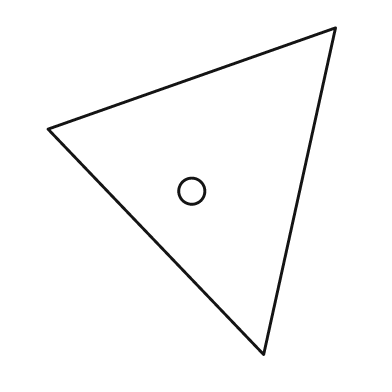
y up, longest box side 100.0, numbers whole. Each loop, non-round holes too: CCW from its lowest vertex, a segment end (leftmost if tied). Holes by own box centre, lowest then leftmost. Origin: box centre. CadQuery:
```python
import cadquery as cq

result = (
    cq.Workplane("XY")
    .moveTo(22.0, -50.0)
    .lineTo(44.0, 50.0)
    .lineTo(-44.0, 19.0)
    .close()
    .moveTo(0.0, 0.0)
    .circle(4.0)
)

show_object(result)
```